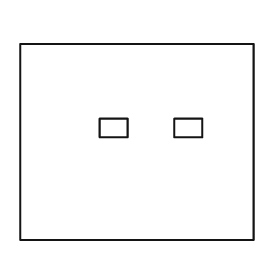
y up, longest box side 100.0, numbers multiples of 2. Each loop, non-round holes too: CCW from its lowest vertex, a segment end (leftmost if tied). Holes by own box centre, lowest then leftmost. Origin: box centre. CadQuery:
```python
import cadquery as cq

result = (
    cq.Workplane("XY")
    .moveTo(-50.0, -42.0)
    .lineTo(50.0, -42.0)
    .lineTo(50.0, 42.0)
    .lineTo(-50.0, 42.0)
    .close()
    .moveTo(-16.0, 2.0)
    .lineTo(-4.0, 2.0)
    .lineTo(-4.0, 10.0)
    .lineTo(-16.0, 10.0)
    .close()
    .moveTo(16.0, 2.0)
    .lineTo(28.0, 2.0)
    .lineTo(28.0, 10.0)
    .lineTo(16.0, 10.0)
    .close()
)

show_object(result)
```